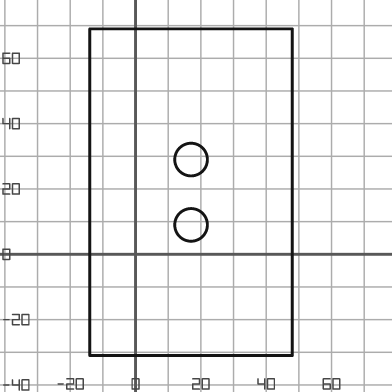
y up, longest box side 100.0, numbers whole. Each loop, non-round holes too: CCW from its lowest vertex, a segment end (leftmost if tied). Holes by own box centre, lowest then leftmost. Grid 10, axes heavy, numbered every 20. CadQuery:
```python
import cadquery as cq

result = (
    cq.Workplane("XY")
    .moveTo(-14.0, -31.0)
    .lineTo(48.0, -31.0)
    .lineTo(48.0, 69.0)
    .lineTo(-14.0, 69.0)
    .close()
    .moveTo(17.0, 9.0)
    .circle(5.0)
    .moveTo(17.0, 29.0)
    .circle(5.0)
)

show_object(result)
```